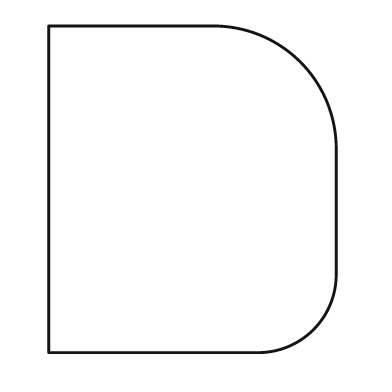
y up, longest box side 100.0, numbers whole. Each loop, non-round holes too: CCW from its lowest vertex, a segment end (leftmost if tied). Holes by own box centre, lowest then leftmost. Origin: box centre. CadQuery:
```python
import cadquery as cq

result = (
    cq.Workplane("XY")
    .moveTo(-44.0, -50.0)
    .lineTo(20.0, -50.0)
    .threePointArc((37.0, -43.0), (44.0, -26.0))
    .lineTo(44.0, 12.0)
    .threePointArc((33.0, 39.0), (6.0, 50.0))
    .lineTo(-44.0, 50.0)
    .close()
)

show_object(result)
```